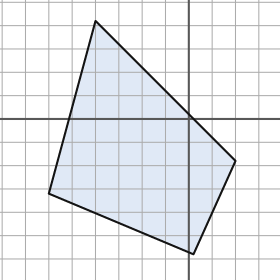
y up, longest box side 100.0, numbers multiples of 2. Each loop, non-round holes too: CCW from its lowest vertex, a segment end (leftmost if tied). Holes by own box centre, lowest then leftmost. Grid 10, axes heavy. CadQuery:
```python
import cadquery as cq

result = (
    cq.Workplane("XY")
    .moveTo(2.0, -58.0)
    .lineTo(20.0, -18.0)
    .lineTo(-40.0, 42.0)
    .lineTo(-60.0, -32.0)
    .close()
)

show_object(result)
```